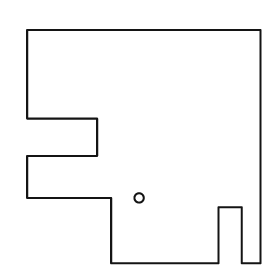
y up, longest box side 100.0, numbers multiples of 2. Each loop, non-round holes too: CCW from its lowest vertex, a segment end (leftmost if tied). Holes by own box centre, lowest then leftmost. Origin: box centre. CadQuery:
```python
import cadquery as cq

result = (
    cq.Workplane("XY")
    .moveTo(-14.0, -50.0)
    .lineTo(32.0, -50.0)
    .lineTo(32.0, -26.0)
    .lineTo(42.0, -26.0)
    .lineTo(42.0, -50.0)
    .lineTo(50.0, -50.0)
    .lineTo(50.0, 50.0)
    .lineTo(-50.0, 50.0)
    .lineTo(-50.0, 12.0)
    .lineTo(-20.0, 12.0)
    .lineTo(-20.0, -4.0)
    .lineTo(-50.0, -4.0)
    .lineTo(-50.0, -22.0)
    .lineTo(-14.0, -22.0)
    .close()
    .moveTo(-2.0, -22.0)
    .circle(2.0)
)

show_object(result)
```